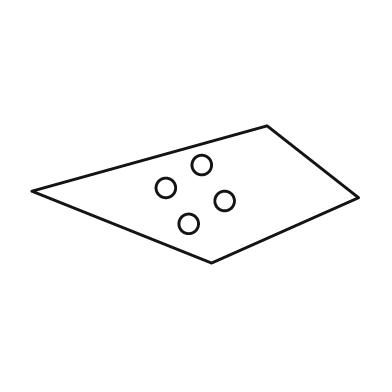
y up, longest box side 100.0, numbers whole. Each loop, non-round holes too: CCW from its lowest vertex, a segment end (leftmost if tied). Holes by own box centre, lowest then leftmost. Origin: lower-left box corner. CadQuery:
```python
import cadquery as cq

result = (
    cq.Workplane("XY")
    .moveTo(55.0, 0.0)
    .lineTo(100.0, 20.0)
    .lineTo(72.0, 42.0)
    .lineTo(0.0, 22.0)
    .close()
    .moveTo(48.0, 12.0)
    .circle(3.0)
    .moveTo(59.0, 19.0)
    .circle(3.0)
    .moveTo(41.0, 23.0)
    .circle(3.0)
    .moveTo(52.0, 30.0)
    .circle(3.0)
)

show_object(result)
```